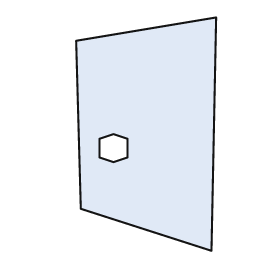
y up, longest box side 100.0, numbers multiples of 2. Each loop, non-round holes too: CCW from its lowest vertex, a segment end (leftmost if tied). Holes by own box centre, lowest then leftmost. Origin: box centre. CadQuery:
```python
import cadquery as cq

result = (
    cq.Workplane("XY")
    .moveTo(28.0, -50.0)
    .lineTo(30.0, 50.0)
    .lineTo(-30.0, 40.0)
    .lineTo(-28.0, -32.0)
    .close()
    .moveTo(-14.0, -12.0)
    .lineTo(-8.0, -10.0)
    .lineTo(-8.0, -2.0)
    .lineTo(-14.0, 0.0)
    .lineTo(-20.0, -2.0)
    .lineTo(-20.0, -10.0)
    .close()
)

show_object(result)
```